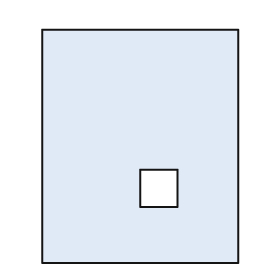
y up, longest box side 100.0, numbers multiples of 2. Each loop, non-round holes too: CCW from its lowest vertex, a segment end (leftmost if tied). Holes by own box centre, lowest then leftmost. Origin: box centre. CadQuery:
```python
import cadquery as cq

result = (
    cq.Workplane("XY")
    .moveTo(-42.0, -50.0)
    .lineTo(42.0, -50.0)
    .lineTo(42.0, 50.0)
    .lineTo(-42.0, 50.0)
    .close()
    .moveTo(0.0, -26.0)
    .lineTo(16.0, -26.0)
    .lineTo(16.0, -10.0)
    .lineTo(0.0, -10.0)
    .close()
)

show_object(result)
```